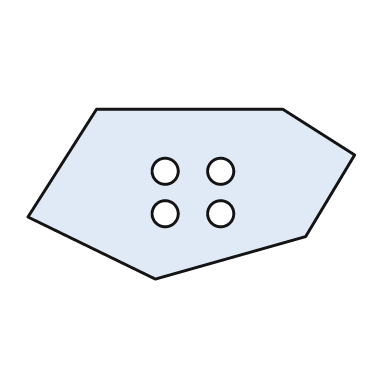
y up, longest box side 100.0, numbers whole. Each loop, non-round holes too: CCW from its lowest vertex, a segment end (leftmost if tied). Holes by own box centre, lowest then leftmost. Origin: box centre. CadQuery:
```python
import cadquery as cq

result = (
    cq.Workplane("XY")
    .moveTo(-11.0, -26.0)
    .lineTo(35.0, -13.0)
    .lineTo(50.0, 12.0)
    .lineTo(28.0, 26.0)
    .lineTo(-29.0, 26.0)
    .lineTo(-50.0, -7.0)
    .close()
    .moveTo(-8.0, -6.0)
    .circle(4.0)
    .moveTo(9.0, -6.0)
    .circle(4.0)
    .moveTo(-8.0, 7.0)
    .circle(4.0)
    .moveTo(9.0, 7.0)
    .circle(4.0)
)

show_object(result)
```